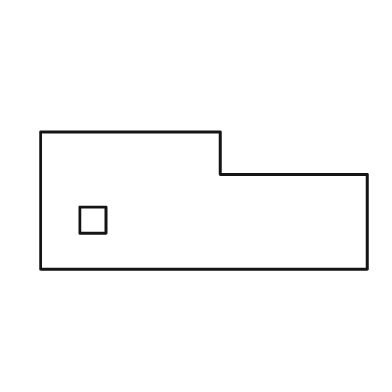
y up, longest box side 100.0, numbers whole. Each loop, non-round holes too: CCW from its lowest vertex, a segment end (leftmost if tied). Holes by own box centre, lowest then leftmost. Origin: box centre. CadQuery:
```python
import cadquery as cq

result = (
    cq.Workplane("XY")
    .moveTo(-50.0, -21.0)
    .lineTo(50.0, -21.0)
    .lineTo(50.0, 8.0)
    .lineTo(5.0, 8.0)
    .lineTo(5.0, 21.0)
    .lineTo(-50.0, 21.0)
    .close()
    .moveTo(-38.0, -10.0)
    .lineTo(-30.0, -10.0)
    .lineTo(-30.0, -2.0)
    .lineTo(-38.0, -2.0)
    .close()
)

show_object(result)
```